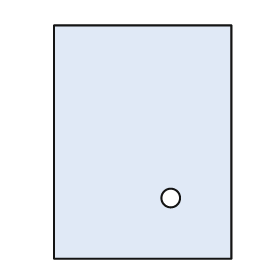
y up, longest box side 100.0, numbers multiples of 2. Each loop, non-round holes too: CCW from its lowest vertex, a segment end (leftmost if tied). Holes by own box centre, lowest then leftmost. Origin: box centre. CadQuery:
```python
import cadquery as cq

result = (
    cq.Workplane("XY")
    .moveTo(-38.0, -50.0)
    .lineTo(38.0, -50.0)
    .lineTo(38.0, 50.0)
    .lineTo(-38.0, 50.0)
    .close()
    .moveTo(12.0, -24.0)
    .circle(4.0)
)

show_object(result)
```